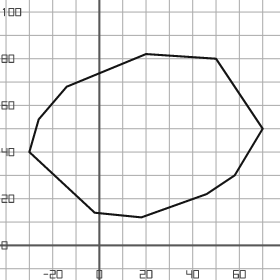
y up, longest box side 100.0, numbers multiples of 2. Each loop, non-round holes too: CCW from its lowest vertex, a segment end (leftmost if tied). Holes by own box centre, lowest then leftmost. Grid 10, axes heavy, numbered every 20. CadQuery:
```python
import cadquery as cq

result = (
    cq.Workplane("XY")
    .moveTo(18.0, 12.0)
    .lineTo(46.0, 22.0)
    .lineTo(58.0, 30.0)
    .lineTo(70.0, 50.0)
    .lineTo(50.0, 80.0)
    .lineTo(20.0, 82.0)
    .lineTo(-14.0, 68.0)
    .lineTo(-26.0, 54.0)
    .lineTo(-30.0, 40.0)
    .lineTo(-2.0, 14.0)
    .close()
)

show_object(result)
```